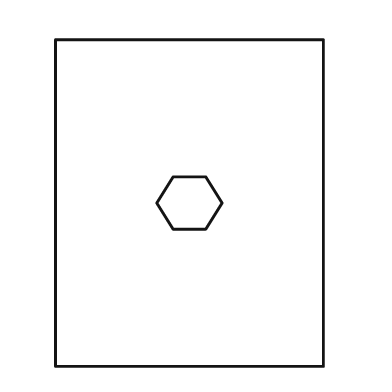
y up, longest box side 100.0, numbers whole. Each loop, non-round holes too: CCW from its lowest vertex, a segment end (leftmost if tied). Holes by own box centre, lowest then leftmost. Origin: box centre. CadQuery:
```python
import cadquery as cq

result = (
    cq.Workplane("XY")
    .moveTo(-41.0, -50.0)
    .lineTo(41.0, -50.0)
    .lineTo(41.0, 50.0)
    .lineTo(-41.0, 50.0)
    .close()
    .moveTo(-5.0, -8.0)
    .lineTo(5.0, -8.0)
    .lineTo(10.0, 0.0)
    .lineTo(5.0, 8.0)
    .lineTo(-5.0, 8.0)
    .lineTo(-10.0, 0.0)
    .close()
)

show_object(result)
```